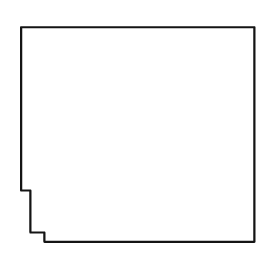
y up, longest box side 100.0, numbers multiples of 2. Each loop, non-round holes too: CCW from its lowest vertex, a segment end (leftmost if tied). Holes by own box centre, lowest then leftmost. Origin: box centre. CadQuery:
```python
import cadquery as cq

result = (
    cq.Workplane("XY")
    .moveTo(-40.0, -46.0)
    .lineTo(50.0, -46.0)
    .lineTo(50.0, 46.0)
    .lineTo(-50.0, 46.0)
    .lineTo(-50.0, -24.0)
    .lineTo(-46.0, -24.0)
    .lineTo(-46.0, -42.0)
    .lineTo(-40.0, -42.0)
    .close()
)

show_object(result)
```